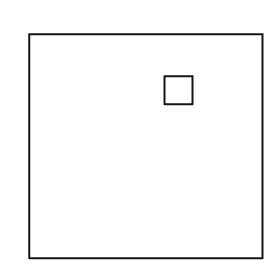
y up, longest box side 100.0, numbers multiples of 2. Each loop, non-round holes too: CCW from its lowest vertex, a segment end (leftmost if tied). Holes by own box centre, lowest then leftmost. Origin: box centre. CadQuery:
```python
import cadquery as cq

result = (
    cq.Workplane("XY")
    .moveTo(-50.0, -48.0)
    .lineTo(50.0, -48.0)
    .lineTo(50.0, 48.0)
    .lineTo(-50.0, 48.0)
    .close()
    .moveTo(8.0, 18.0)
    .lineTo(20.0, 18.0)
    .lineTo(20.0, 30.0)
    .lineTo(8.0, 30.0)
    .close()
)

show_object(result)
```